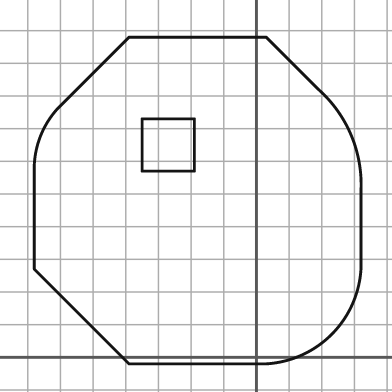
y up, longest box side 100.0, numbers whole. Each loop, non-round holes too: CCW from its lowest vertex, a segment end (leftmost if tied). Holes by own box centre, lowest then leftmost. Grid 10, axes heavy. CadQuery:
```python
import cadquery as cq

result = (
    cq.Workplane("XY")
    .moveTo(-39.0, -2.0)
    .lineTo(3.0, -2.0)
    .threePointArc((23.0, 7.0), (32.0, 27.0))
    .lineTo(32.0, 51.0)
    .threePointArc((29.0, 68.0), (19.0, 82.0))
    .lineTo(3.0, 98.0)
    .lineTo(-39.0, 98.0)
    .lineTo(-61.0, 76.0)
    .threePointArc((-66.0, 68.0), (-68.0, 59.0))
    .lineTo(-68.0, 27.0)
    .close()
    .moveTo(-35.0, 57.0)
    .lineTo(-19.0, 57.0)
    .lineTo(-19.0, 73.0)
    .lineTo(-35.0, 73.0)
    .close()
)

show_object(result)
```